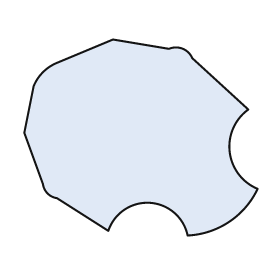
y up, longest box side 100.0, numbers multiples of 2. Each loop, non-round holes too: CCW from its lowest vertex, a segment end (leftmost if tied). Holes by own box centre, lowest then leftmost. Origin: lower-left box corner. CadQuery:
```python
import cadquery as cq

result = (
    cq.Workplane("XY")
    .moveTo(70.0, 0.0)
    .threePointArc((88.0, 6.0), (100.0, 20.0))
    .threePointArc((88.0, 36.0), (96.0, 54.0))
    .lineTo(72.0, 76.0)
    .threePointArc((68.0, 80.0), (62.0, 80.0))
    .lineTo(38.0, 84.0)
    .lineTo(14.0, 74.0)
    .threePointArc((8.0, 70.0), (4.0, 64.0))
    .lineTo(0.0, 44.0)
    .lineTo(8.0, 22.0)
    .threePointArc((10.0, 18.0), (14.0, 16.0))
    .lineTo(36.0, 2.0)
    .threePointArc((54.0, 14.0), (70.0, 0.0))
    .close()
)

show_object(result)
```